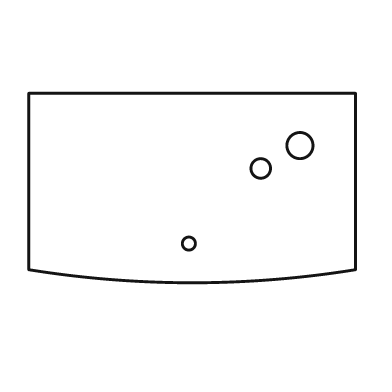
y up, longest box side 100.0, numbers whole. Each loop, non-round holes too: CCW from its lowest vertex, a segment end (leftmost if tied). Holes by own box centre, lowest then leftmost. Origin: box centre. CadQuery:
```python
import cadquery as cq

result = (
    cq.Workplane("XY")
    .moveTo(-50.0, -25.0)
    .threePointArc((0.0, -29.0), (50.0, -25.0))
    .lineTo(50.0, 29.0)
    .lineTo(-50.0, 29.0)
    .close()
    .moveTo(-1.0, -17.0)
    .circle(2.0)
    .moveTo(21.0, 6.0)
    .circle(3.0)
    .moveTo(33.0, 13.0)
    .circle(4.0)
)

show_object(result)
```